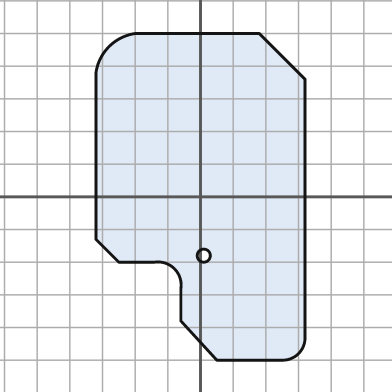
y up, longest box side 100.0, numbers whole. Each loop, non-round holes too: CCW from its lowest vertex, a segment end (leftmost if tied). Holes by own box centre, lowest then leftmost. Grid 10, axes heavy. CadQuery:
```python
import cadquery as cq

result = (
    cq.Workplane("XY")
    .moveTo(5.0, -50.0)
    .lineTo(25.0, -50.0)
    .threePointArc((30.0, -48.0), (32.0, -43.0))
    .lineTo(32.0, 36.0)
    .lineTo(18.0, 50.0)
    .lineTo(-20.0, 50.0)
    .threePointArc((-28.0, 46.0), (-32.0, 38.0))
    .lineTo(-32.0, -13.0)
    .lineTo(-25.0, -20.0)
    .lineTo(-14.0, -20.0)
    .threePointArc((-8.0, -22.0), (-6.0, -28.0))
    .lineTo(-6.0, -38.0)
    .close()
    .moveTo(1.0, -18.0)
    .circle(2.0)
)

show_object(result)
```